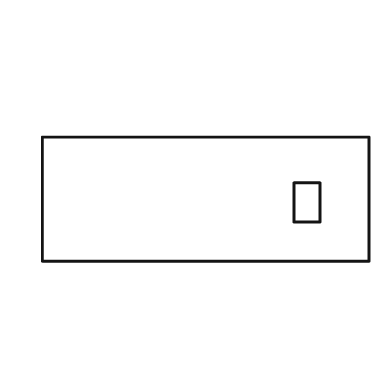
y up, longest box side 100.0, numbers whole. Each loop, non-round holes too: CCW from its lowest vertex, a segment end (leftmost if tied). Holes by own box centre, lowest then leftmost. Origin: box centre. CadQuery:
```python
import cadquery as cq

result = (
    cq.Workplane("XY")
    .moveTo(-50.0, -19.0)
    .lineTo(50.0, -19.0)
    .lineTo(50.0, 19.0)
    .lineTo(-50.0, 19.0)
    .close()
    .moveTo(27.0, -7.0)
    .lineTo(35.0, -7.0)
    .lineTo(35.0, 5.0)
    .lineTo(27.0, 5.0)
    .close()
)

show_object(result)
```